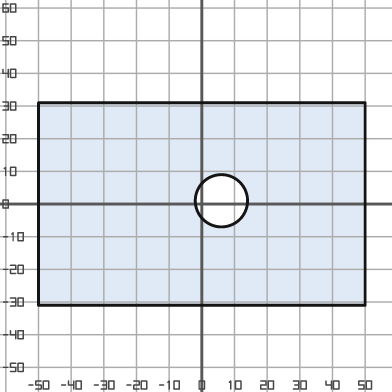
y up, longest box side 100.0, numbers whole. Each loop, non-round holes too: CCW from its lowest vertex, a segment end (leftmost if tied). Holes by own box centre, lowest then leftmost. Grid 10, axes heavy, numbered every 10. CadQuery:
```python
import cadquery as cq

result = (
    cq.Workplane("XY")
    .moveTo(-50.0, -31.0)
    .lineTo(50.0, -31.0)
    .lineTo(50.0, 31.0)
    .lineTo(-50.0, 31.0)
    .close()
    .moveTo(6.0, 1.0)
    .circle(8.0)
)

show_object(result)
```